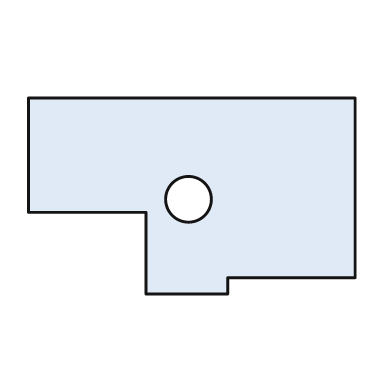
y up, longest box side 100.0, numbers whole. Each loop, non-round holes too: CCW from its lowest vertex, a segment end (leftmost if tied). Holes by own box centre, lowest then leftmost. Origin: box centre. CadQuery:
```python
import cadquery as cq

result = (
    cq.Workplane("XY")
    .moveTo(-14.0, -30.0)
    .lineTo(11.0, -30.0)
    .lineTo(11.0, -25.0)
    .lineTo(50.0, -25.0)
    .lineTo(50.0, 30.0)
    .lineTo(-50.0, 30.0)
    .lineTo(-50.0, -5.0)
    .lineTo(-14.0, -5.0)
    .close()
    .moveTo(-1.0, -1.0)
    .circle(7.0)
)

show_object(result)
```